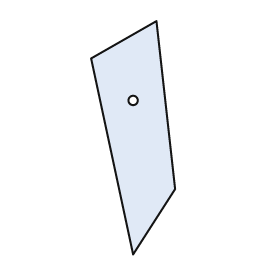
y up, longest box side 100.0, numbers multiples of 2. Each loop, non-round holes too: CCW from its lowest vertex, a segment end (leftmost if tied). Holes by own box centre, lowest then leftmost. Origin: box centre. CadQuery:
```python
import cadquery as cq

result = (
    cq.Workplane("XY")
    .moveTo(0.0, -50.0)
    .lineTo(18.0, -22.0)
    .lineTo(10.0, 50.0)
    .lineTo(-18.0, 34.0)
    .close()
    .moveTo(0.0, 16.0)
    .circle(2.0)
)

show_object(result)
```